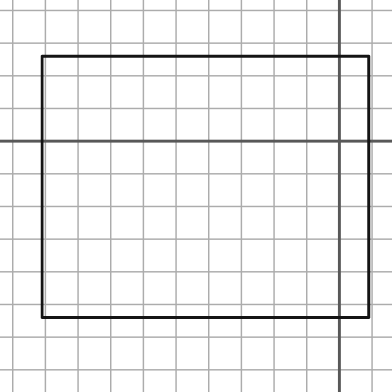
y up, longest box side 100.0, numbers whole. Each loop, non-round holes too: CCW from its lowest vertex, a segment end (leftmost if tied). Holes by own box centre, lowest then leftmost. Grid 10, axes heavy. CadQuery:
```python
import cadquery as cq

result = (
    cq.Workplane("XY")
    .moveTo(-91.0, -54.0)
    .lineTo(9.0, -54.0)
    .lineTo(9.0, 26.0)
    .lineTo(-91.0, 26.0)
    .close()
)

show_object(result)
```